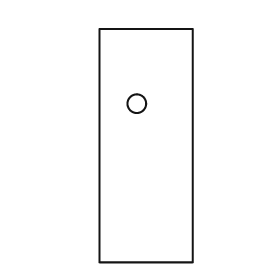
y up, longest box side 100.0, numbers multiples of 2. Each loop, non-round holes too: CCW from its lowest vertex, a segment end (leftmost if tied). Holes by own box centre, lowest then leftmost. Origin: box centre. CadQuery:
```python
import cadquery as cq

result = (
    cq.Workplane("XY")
    .moveTo(-20.0, -50.0)
    .lineTo(20.0, -50.0)
    .lineTo(20.0, 50.0)
    .lineTo(-20.0, 50.0)
    .close()
    .moveTo(-4.0, 18.0)
    .circle(4.0)
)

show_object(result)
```